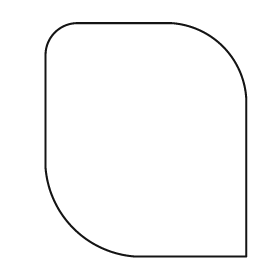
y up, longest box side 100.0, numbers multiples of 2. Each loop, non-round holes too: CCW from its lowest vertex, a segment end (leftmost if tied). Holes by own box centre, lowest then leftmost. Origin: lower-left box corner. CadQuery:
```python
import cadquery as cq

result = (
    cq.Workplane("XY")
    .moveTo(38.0, 0.0)
    .lineTo(86.0, 0.0)
    .lineTo(86.0, 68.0)
    .threePointArc((76.0, 90.0), (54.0, 100.0))
    .lineTo(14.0, 100.0)
    .threePointArc((4.0, 96.0), (0.0, 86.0))
    .lineTo(0.0, 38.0)
    .threePointArc((12.0, 12.0), (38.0, 0.0))
    .close()
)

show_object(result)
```